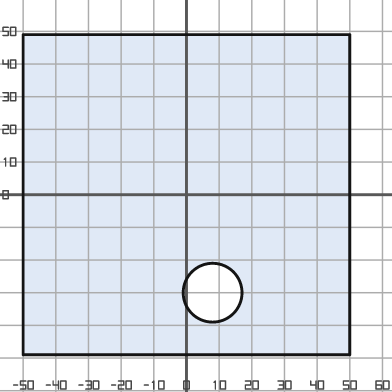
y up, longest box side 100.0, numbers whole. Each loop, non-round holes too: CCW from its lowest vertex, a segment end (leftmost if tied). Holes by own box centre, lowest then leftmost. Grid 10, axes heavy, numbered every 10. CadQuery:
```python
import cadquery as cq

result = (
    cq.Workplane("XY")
    .moveTo(-50.0, -49.0)
    .lineTo(50.0, -49.0)
    .lineTo(50.0, 49.0)
    .lineTo(-50.0, 49.0)
    .close()
    .moveTo(8.0, -30.0)
    .circle(9.0)
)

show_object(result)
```